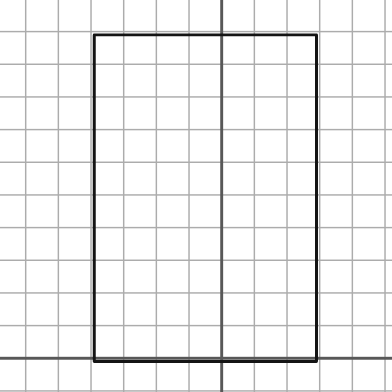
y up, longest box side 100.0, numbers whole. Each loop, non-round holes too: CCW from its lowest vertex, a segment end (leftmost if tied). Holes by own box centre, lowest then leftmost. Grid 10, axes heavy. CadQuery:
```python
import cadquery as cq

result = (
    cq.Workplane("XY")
    .moveTo(-39.0, -1.0)
    .lineTo(29.0, -1.0)
    .lineTo(29.0, 99.0)
    .lineTo(-39.0, 99.0)
    .close()
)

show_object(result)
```